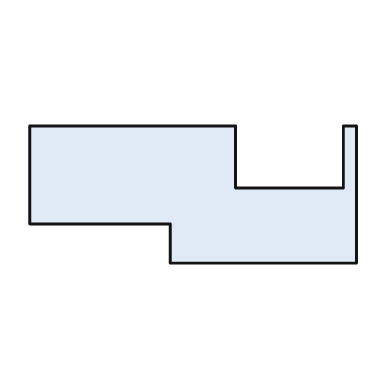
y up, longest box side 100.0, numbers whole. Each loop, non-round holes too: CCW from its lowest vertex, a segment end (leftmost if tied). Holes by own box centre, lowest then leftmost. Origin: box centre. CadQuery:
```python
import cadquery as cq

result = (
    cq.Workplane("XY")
    .moveTo(-7.0, -21.0)
    .lineTo(50.0, -21.0)
    .lineTo(50.0, 21.0)
    .lineTo(46.0, 21.0)
    .lineTo(46.0, 2.0)
    .lineTo(13.0, 2.0)
    .lineTo(13.0, 21.0)
    .lineTo(-50.0, 21.0)
    .lineTo(-50.0, -9.0)
    .lineTo(-7.0, -9.0)
    .close()
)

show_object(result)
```